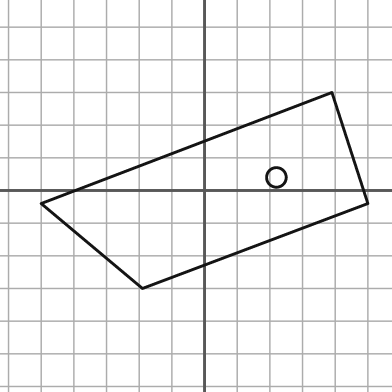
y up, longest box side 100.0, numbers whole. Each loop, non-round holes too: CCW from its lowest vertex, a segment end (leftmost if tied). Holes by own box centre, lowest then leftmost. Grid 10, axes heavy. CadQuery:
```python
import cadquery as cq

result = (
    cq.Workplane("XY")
    .moveTo(-19.0, -30.0)
    .lineTo(50.0, -4.0)
    .lineTo(39.0, 30.0)
    .lineTo(-50.0, -4.0)
    .close()
    .moveTo(22.0, 4.0)
    .circle(3.0)
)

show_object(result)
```